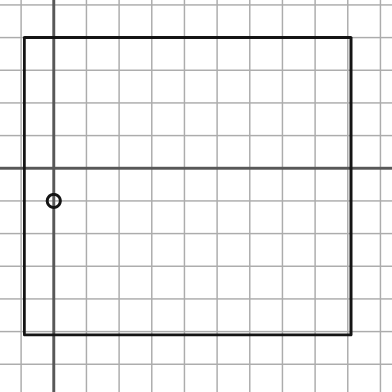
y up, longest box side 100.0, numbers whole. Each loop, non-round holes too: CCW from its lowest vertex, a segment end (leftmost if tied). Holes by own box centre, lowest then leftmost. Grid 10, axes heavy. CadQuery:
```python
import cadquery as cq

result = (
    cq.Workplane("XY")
    .moveTo(-9.0, -51.0)
    .lineTo(91.0, -51.0)
    .lineTo(91.0, 40.0)
    .lineTo(-9.0, 40.0)
    .close()
    .moveTo(0.0, -10.0)
    .circle(2.0)
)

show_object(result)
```